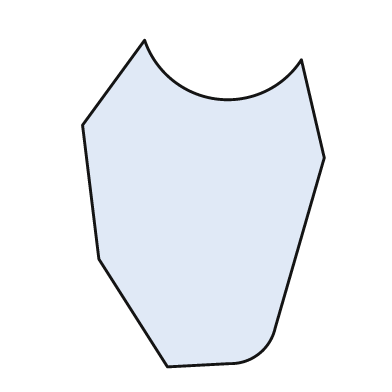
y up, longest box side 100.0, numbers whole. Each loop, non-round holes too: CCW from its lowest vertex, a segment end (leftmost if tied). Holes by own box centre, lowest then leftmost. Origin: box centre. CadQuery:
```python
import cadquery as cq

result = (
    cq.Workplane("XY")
    .moveTo(-11.0, -50.0)
    .lineTo(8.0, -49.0)
    .threePointArc((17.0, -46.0), (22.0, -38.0))
    .lineTo(37.0, 14.0)
    .lineTo(30.0, 44.0)
    .threePointArc((4.0, 32.0), (-18.0, 50.0))
    .lineTo(-37.0, 24.0)
    .lineTo(-32.0, -17.0)
    .close()
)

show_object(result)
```